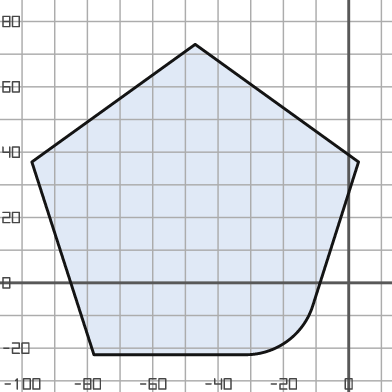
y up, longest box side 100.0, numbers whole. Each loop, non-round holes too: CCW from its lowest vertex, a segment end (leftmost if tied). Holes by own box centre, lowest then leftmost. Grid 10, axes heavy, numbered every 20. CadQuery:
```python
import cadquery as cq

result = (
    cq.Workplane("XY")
    .moveTo(-78.0, -22.0)
    .lineTo(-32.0, -22.0)
    .threePointArc((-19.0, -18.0), (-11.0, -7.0))
    .lineTo(3.0, 37.0)
    .lineTo(-47.0, 73.0)
    .lineTo(-97.0, 37.0)
    .close()
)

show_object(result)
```